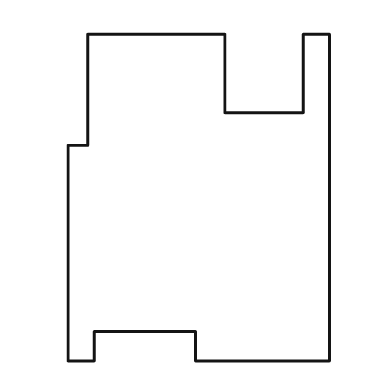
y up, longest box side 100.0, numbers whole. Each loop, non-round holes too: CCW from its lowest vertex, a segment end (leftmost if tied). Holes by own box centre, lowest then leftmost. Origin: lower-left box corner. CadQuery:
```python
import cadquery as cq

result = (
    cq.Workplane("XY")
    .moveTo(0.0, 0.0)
    .lineTo(8.0, 0.0)
    .lineTo(8.0, 9.0)
    .lineTo(39.0, 9.0)
    .lineTo(39.0, 0.0)
    .lineTo(80.0, 0.0)
    .lineTo(80.0, 100.0)
    .lineTo(72.0, 100.0)
    .lineTo(72.0, 76.0)
    .lineTo(48.0, 76.0)
    .lineTo(48.0, 100.0)
    .lineTo(6.0, 100.0)
    .lineTo(6.0, 66.0)
    .lineTo(0.0, 66.0)
    .close()
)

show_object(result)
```